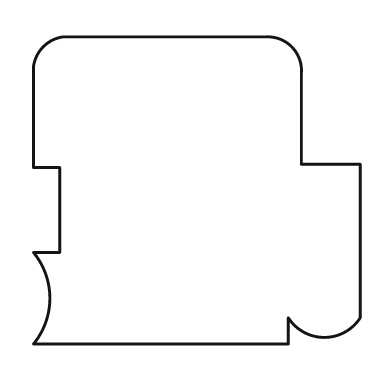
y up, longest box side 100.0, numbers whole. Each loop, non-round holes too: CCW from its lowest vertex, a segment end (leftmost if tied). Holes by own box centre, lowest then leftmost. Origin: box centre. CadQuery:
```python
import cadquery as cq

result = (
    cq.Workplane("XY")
    .moveTo(-50.0, -47.0)
    .lineTo(28.0, -47.0)
    .lineTo(28.0, -39.0)
    .threePointArc((39.0, -45.0), (50.0, -39.0))
    .lineTo(50.0, 8.0)
    .lineTo(32.0, 8.0)
    .lineTo(32.0, 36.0)
    .threePointArc((29.0, 44.0), (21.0, 47.0))
    .lineTo(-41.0, 47.0)
    .threePointArc((-47.0, 44.0), (-50.0, 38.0))
    .lineTo(-50.0, 7.0)
    .lineTo(-42.0, 7.0)
    .lineTo(-42.0, -19.0)
    .lineTo(-50.0, -19.0)
    .threePointArc((-45.0, -33.0), (-50.0, -47.0))
    .close()
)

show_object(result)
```